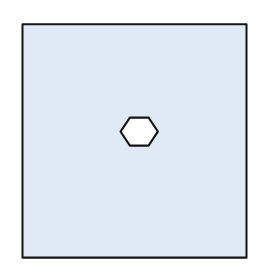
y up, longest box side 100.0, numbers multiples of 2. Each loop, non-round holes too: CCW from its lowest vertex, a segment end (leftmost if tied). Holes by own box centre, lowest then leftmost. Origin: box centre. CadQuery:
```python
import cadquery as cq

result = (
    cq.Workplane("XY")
    .moveTo(-48.0, -50.0)
    .lineTo(48.0, -50.0)
    .lineTo(48.0, 50.0)
    .lineTo(-48.0, 50.0)
    .close()
    .moveTo(-2.0, -2.0)
    .lineTo(6.0, -2.0)
    .lineTo(10.0, 4.0)
    .lineTo(6.0, 10.0)
    .lineTo(-2.0, 10.0)
    .lineTo(-6.0, 4.0)
    .close()
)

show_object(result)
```